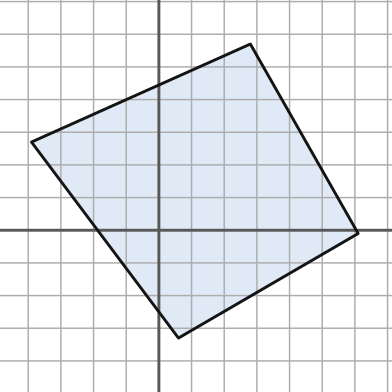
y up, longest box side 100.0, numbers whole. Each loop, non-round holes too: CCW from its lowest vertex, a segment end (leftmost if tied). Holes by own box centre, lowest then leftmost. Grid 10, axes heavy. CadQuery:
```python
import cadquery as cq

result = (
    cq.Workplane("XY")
    .moveTo(6.0, -33.0)
    .lineTo(61.0, -1.0)
    .lineTo(28.0, 57.0)
    .lineTo(-39.0, 27.0)
    .close()
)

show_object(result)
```